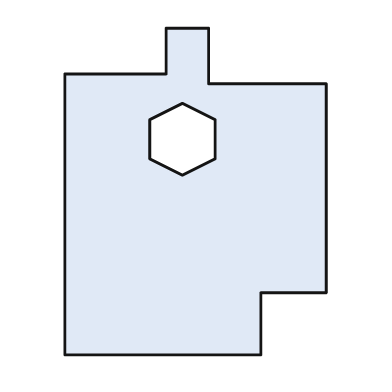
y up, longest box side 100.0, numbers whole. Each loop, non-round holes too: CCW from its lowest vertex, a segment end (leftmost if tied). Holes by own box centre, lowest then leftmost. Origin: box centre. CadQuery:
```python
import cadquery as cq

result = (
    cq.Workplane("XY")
    .moveTo(-40.0, -50.0)
    .lineTo(20.0, -50.0)
    .lineTo(20.0, -31.0)
    .lineTo(40.0, -31.0)
    .lineTo(40.0, 33.0)
    .lineTo(4.0, 33.0)
    .lineTo(4.0, 50.0)
    .lineTo(-9.0, 50.0)
    .lineTo(-9.0, 36.0)
    .lineTo(-40.0, 36.0)
    .close()
    .moveTo(-4.0, 5.0)
    .lineTo(6.0, 10.0)
    .lineTo(6.0, 22.0)
    .lineTo(-4.0, 27.0)
    .lineTo(-14.0, 22.0)
    .lineTo(-14.0, 10.0)
    .close()
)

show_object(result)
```